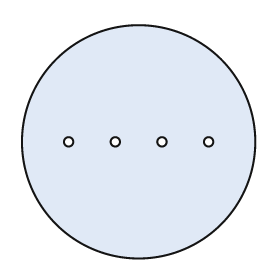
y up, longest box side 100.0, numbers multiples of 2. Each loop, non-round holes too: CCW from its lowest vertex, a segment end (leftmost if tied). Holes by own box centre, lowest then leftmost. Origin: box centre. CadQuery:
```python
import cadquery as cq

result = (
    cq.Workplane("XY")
    .moveTo(0.0, 0.0)
    .circle(50.0)
    .moveTo(-30.0, 0.0)
    .circle(2.0)
    .moveTo(-10.0, 0.0)
    .circle(2.0)
    .moveTo(10.0, 0.0)
    .circle(2.0)
    .moveTo(30.0, 0.0)
    .circle(2.0)
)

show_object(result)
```